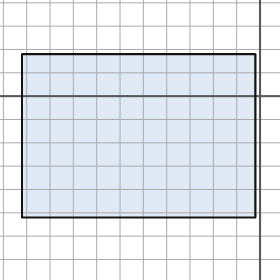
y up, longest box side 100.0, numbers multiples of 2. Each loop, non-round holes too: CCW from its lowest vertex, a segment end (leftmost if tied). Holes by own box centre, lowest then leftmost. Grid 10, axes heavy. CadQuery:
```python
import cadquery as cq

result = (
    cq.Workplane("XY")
    .moveTo(-102.0, -52.0)
    .lineTo(-2.0, -52.0)
    .lineTo(-2.0, 18.0)
    .lineTo(-102.0, 18.0)
    .close()
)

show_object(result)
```